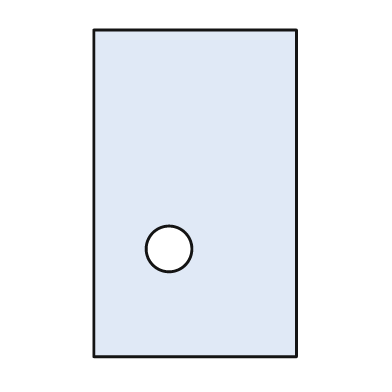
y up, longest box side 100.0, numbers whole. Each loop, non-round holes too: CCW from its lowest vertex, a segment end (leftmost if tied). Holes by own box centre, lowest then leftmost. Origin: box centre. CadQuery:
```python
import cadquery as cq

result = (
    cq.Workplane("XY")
    .moveTo(-31.0, -50.0)
    .lineTo(31.0, -50.0)
    .lineTo(31.0, 50.0)
    .lineTo(-31.0, 50.0)
    .close()
    .moveTo(-8.0, -17.0)
    .circle(7.0)
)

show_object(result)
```